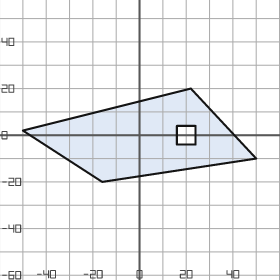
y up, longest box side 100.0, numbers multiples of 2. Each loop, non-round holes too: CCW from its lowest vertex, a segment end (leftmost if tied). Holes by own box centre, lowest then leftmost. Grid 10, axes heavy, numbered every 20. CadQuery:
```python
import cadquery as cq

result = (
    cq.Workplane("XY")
    .moveTo(-16.0, -20.0)
    .lineTo(50.0, -10.0)
    .lineTo(22.0, 20.0)
    .lineTo(-50.0, 2.0)
    .close()
    .moveTo(16.0, -4.0)
    .lineTo(24.0, -4.0)
    .lineTo(24.0, 4.0)
    .lineTo(16.0, 4.0)
    .close()
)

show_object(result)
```